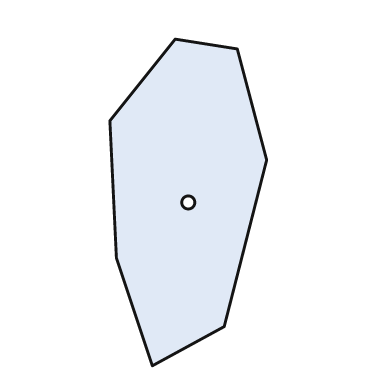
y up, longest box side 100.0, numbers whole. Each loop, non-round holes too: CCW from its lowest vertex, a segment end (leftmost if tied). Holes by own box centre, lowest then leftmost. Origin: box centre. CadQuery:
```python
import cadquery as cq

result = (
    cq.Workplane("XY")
    .moveTo(-11.0, -50.0)
    .lineTo(11.0, -38.0)
    .lineTo(24.0, 13.0)
    .lineTo(15.0, 47.0)
    .lineTo(-4.0, 50.0)
    .lineTo(-24.0, 25.0)
    .lineTo(-22.0, -17.0)
    .close()
    .moveTo(0.0, 0.0)
    .circle(2.0)
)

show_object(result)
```